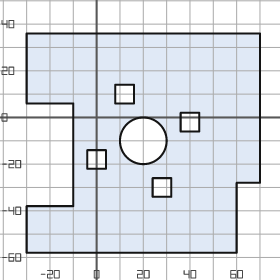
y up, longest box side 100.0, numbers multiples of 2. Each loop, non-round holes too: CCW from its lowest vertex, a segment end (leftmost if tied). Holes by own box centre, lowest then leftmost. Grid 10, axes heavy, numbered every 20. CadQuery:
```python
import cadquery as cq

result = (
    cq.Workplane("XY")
    .moveTo(-30.0, -58.0)
    .lineTo(60.0, -58.0)
    .lineTo(60.0, -28.0)
    .lineTo(70.0, -28.0)
    .lineTo(70.0, 36.0)
    .lineTo(-30.0, 36.0)
    .lineTo(-30.0, 6.0)
    .lineTo(-10.0, 6.0)
    .lineTo(-10.0, -38.0)
    .lineTo(-30.0, -38.0)
    .close()
    .moveTo(24.0, -34.0)
    .lineTo(32.0, -34.0)
    .lineTo(32.0, -26.0)
    .lineTo(24.0, -26.0)
    .close()
    .moveTo(-4.0, -22.0)
    .lineTo(4.0, -22.0)
    .lineTo(4.0, -14.0)
    .lineTo(-4.0, -14.0)
    .close()
    .moveTo(20.0, -10.0)
    .circle(10.0)
    .moveTo(36.0, -6.0)
    .lineTo(44.0, -6.0)
    .lineTo(44.0, 2.0)
    .lineTo(36.0, 2.0)
    .close()
    .moveTo(8.0, 6.0)
    .lineTo(16.0, 6.0)
    .lineTo(16.0, 14.0)
    .lineTo(8.0, 14.0)
    .close()
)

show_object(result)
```